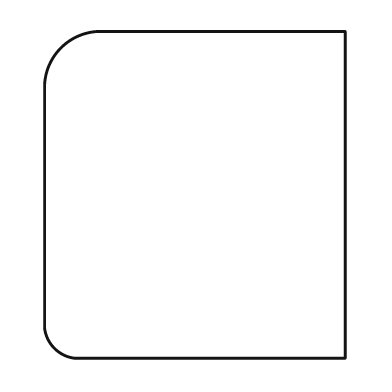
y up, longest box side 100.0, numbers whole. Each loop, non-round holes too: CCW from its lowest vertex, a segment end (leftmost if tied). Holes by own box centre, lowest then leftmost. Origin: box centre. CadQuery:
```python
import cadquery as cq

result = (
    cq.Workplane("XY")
    .moveTo(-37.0, -50.0)
    .lineTo(46.0, -50.0)
    .lineTo(46.0, 50.0)
    .lineTo(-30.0, 50.0)
    .threePointArc((-41.0, 45.0), (-46.0, 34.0))
    .lineTo(-46.0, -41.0)
    .threePointArc((-43.0, -47.0), (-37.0, -50.0))
    .close()
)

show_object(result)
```